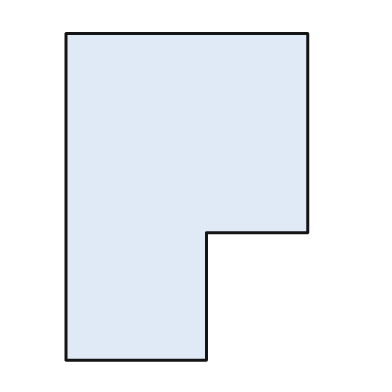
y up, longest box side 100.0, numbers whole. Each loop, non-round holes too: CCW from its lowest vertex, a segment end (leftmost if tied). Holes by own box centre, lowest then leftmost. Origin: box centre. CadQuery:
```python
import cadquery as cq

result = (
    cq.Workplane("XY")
    .moveTo(-37.0, -50.0)
    .lineTo(6.0, -50.0)
    .lineTo(6.0, -11.0)
    .lineTo(37.0, -11.0)
    .lineTo(37.0, 50.0)
    .lineTo(-37.0, 50.0)
    .close()
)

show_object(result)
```